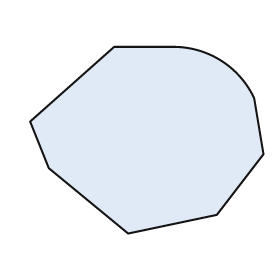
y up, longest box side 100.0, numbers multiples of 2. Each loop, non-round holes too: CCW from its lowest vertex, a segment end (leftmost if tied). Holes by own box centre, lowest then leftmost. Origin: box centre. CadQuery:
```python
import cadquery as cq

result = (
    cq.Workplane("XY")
    .moveTo(-8.0, -40.0)
    .lineTo(30.0, -32.0)
    .lineTo(50.0, -6.0)
    .lineTo(46.0, 18.0)
    .threePointArc((32.0, 34.0), (12.0, 40.0))
    .lineTo(-14.0, 40.0)
    .lineTo(-50.0, 8.0)
    .lineTo(-42.0, -12.0)
    .close()
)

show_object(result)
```